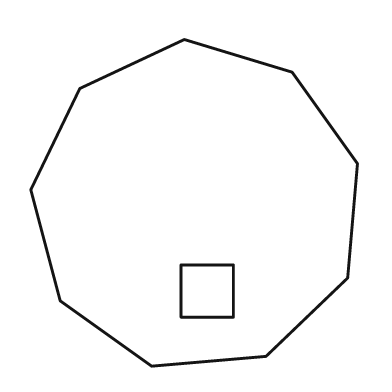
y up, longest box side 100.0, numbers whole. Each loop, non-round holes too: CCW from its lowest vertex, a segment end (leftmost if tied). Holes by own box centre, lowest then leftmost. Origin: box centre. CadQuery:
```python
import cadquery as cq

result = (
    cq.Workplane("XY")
    .moveTo(-13.0, -50.0)
    .lineTo(22.0, -47.0)
    .lineTo(47.0, -23.0)
    .lineTo(50.0, 12.0)
    .lineTo(30.0, 40.0)
    .lineTo(-3.0, 50.0)
    .lineTo(-35.0, 35.0)
    .lineTo(-50.0, 4.0)
    .lineTo(-41.0, -30.0)
    .close()
    .moveTo(-4.0, -35.0)
    .lineTo(12.0, -35.0)
    .lineTo(12.0, -19.0)
    .lineTo(-4.0, -19.0)
    .close()
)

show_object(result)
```